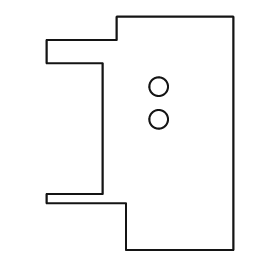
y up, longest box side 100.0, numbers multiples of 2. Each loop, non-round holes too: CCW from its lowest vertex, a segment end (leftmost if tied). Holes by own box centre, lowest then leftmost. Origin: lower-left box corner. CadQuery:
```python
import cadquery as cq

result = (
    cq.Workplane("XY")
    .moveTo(34.0, 0.0)
    .lineTo(80.0, 0.0)
    .lineTo(80.0, 100.0)
    .lineTo(30.0, 100.0)
    .lineTo(30.0, 90.0)
    .lineTo(0.0, 90.0)
    .lineTo(0.0, 80.0)
    .lineTo(24.0, 80.0)
    .lineTo(24.0, 24.0)
    .lineTo(0.0, 24.0)
    .lineTo(0.0, 20.0)
    .lineTo(34.0, 20.0)
    .close()
    .moveTo(48.0, 56.0)
    .circle(4.0)
    .moveTo(48.0, 70.0)
    .circle(4.0)
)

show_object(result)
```